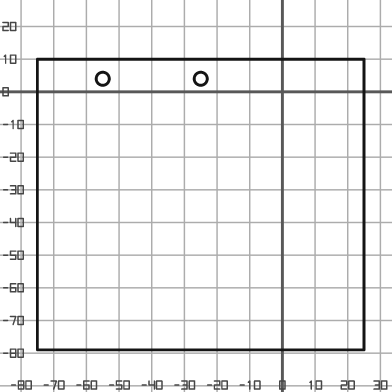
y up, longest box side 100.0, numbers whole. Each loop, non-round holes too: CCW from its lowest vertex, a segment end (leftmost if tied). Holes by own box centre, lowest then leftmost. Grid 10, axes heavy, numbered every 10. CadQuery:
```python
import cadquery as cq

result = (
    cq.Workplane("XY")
    .moveTo(-75.0, -79.0)
    .lineTo(25.0, -79.0)
    .lineTo(25.0, 10.0)
    .lineTo(-75.0, 10.0)
    .close()
    .moveTo(-55.0, 4.0)
    .circle(2.0)
    .moveTo(-25.0, 4.0)
    .circle(2.0)
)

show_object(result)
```